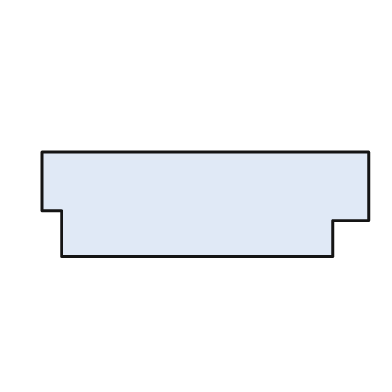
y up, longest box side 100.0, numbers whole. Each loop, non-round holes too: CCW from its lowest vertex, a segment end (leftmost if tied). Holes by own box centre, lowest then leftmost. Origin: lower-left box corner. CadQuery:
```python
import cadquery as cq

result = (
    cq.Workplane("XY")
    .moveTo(6.0, 0.0)
    .lineTo(89.0, 0.0)
    .lineTo(89.0, 11.0)
    .lineTo(100.0, 11.0)
    .lineTo(100.0, 32.0)
    .lineTo(0.0, 32.0)
    .lineTo(0.0, 14.0)
    .lineTo(6.0, 14.0)
    .close()
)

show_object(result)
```